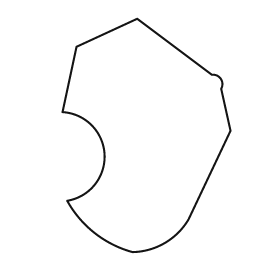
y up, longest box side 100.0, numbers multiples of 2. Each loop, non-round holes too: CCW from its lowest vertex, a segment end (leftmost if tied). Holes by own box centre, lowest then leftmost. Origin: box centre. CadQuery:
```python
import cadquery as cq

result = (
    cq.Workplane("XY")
    .moveTo(-6.0, -50.0)
    .threePointArc((8.0, -46.0), (18.0, -36.0))
    .lineTo(36.0, 2.0)
    .lineTo(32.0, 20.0)
    .threePointArc((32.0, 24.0), (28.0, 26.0))
    .lineTo(-4.0, 50.0)
    .lineTo(-30.0, 38.0)
    .lineTo(-36.0, 10.0)
    .threePointArc((-18.0, -8.0), (-34.0, -28.0))
    .threePointArc((-22.0, -42.0), (-6.0, -50.0))
    .close()
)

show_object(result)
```